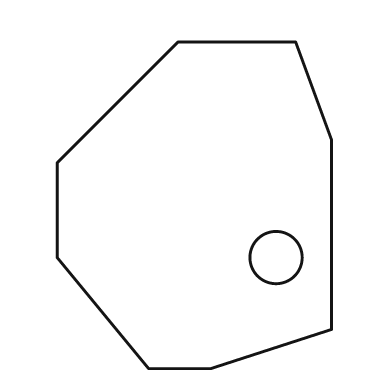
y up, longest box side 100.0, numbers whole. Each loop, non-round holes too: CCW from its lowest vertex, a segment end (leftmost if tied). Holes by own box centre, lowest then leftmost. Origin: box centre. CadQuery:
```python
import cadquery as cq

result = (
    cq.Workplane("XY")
    .moveTo(-14.0, -50.0)
    .lineTo(5.0, -50.0)
    .lineTo(42.0, -38.0)
    .lineTo(42.0, 20.0)
    .lineTo(31.0, 50.0)
    .lineTo(-5.0, 50.0)
    .lineTo(-42.0, 13.0)
    .lineTo(-42.0, -16.0)
    .close()
    .moveTo(25.0, -16.0)
    .circle(8.0)
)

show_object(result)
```